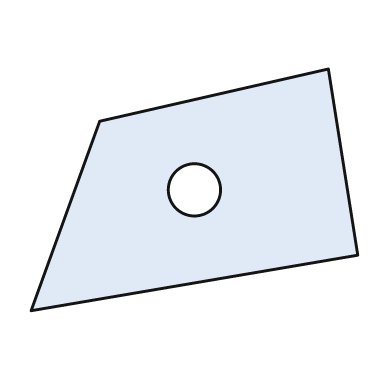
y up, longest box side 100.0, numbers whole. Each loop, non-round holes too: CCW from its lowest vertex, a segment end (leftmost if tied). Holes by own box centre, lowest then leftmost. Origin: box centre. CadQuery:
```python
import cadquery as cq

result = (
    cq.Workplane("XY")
    .moveTo(-50.0, -37.0)
    .lineTo(50.0, -20.0)
    .lineTo(41.0, 37.0)
    .lineTo(-29.0, 21.0)
    .close()
    .moveTo(0.0, 0.0)
    .circle(8.0)
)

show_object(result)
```